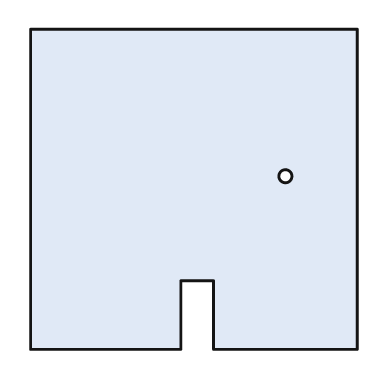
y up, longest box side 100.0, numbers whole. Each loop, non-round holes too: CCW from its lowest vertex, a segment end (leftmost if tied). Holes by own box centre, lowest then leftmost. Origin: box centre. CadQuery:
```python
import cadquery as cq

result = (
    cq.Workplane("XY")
    .moveTo(-50.0, -49.0)
    .lineTo(-4.0, -49.0)
    .lineTo(-4.0, -28.0)
    .lineTo(6.0, -28.0)
    .lineTo(6.0, -49.0)
    .lineTo(50.0, -49.0)
    .lineTo(50.0, 49.0)
    .lineTo(-50.0, 49.0)
    .close()
    .moveTo(28.0, 4.0)
    .circle(2.0)
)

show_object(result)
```